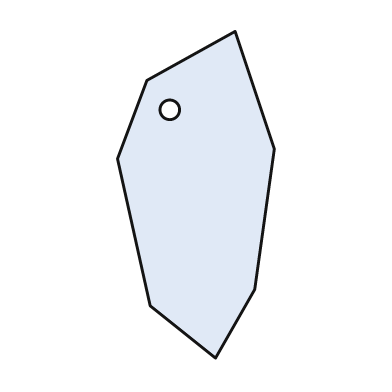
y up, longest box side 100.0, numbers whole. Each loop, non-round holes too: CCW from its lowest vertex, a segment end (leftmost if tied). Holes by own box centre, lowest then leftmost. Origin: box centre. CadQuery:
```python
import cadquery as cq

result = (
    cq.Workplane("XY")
    .moveTo(6.0, -50.0)
    .lineTo(18.0, -29.0)
    .lineTo(24.0, 14.0)
    .lineTo(12.0, 50.0)
    .lineTo(-15.0, 35.0)
    .lineTo(-24.0, 11.0)
    .lineTo(-14.0, -34.0)
    .close()
    .moveTo(-8.0, 26.0)
    .circle(3.0)
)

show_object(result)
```